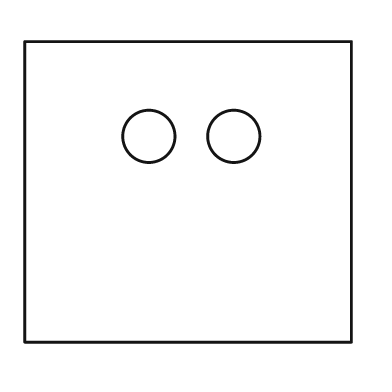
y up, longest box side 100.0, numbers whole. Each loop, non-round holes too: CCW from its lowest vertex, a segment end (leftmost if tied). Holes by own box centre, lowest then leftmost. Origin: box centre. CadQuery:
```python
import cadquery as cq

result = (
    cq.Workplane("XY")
    .moveTo(-50.0, -46.0)
    .lineTo(50.0, -46.0)
    .lineTo(50.0, 46.0)
    .lineTo(-50.0, 46.0)
    .close()
    .moveTo(-12.0, 17.0)
    .circle(8.0)
    .moveTo(14.0, 17.0)
    .circle(8.0)
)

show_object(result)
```